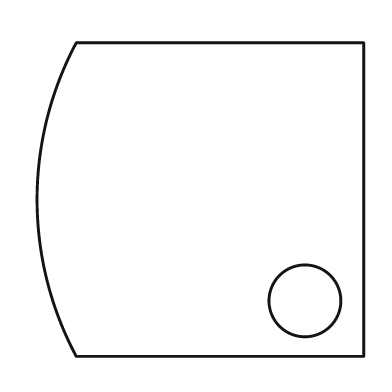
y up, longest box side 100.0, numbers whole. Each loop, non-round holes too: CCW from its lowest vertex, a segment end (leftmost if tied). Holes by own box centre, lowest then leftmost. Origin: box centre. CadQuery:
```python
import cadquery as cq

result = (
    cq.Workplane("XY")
    .moveTo(-38.0, -48.0)
    .lineTo(50.0, -48.0)
    .lineTo(50.0, 48.0)
    .lineTo(-38.0, 48.0)
    .threePointArc((-50.0, 0.0), (-38.0, -48.0))
    .close()
    .moveTo(32.0, -31.0)
    .circle(11.0)
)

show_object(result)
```